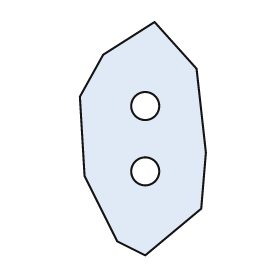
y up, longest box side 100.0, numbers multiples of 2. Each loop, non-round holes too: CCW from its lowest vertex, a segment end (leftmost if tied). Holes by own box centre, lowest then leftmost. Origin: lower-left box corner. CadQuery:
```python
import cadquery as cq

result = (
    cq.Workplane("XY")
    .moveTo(28.0, 0.0)
    .lineTo(52.0, 20.0)
    .lineTo(54.0, 44.0)
    .lineTo(50.0, 80.0)
    .lineTo(32.0, 100.0)
    .lineTo(10.0, 86.0)
    .lineTo(0.0, 68.0)
    .lineTo(2.0, 34.0)
    .lineTo(16.0, 6.0)
    .close()
    .moveTo(28.0, 36.0)
    .circle(6.0)
    .moveTo(28.0, 64.0)
    .circle(6.0)
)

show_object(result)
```